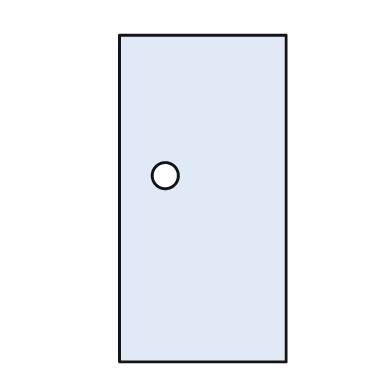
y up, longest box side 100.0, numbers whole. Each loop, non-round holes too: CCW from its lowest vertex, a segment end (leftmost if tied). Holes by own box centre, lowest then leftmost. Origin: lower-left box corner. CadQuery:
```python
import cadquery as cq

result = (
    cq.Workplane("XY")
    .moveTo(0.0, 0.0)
    .lineTo(51.0, 0.0)
    .lineTo(51.0, 100.0)
    .lineTo(0.0, 100.0)
    .close()
    .moveTo(14.0, 57.0)
    .circle(4.0)
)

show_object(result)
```